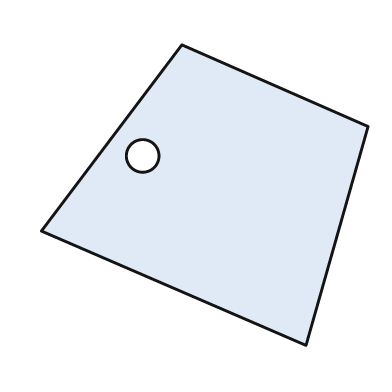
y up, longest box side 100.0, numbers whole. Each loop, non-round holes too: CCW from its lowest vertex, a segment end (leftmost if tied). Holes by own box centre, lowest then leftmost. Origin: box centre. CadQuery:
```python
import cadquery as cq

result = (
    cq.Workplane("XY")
    .moveTo(31.0, -46.0)
    .lineTo(50.0, 21.0)
    .lineTo(-7.0, 46.0)
    .lineTo(-50.0, -11.0)
    .close()
    .moveTo(-19.0, 12.0)
    .circle(5.0)
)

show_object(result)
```